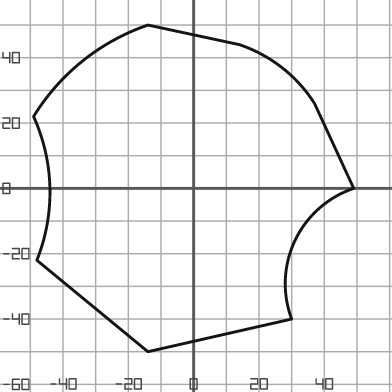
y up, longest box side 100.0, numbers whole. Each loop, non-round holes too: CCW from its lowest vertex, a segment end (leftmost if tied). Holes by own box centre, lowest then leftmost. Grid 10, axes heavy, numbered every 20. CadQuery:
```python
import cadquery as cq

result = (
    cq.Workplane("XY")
    .moveTo(-14.0, -50.0)
    .lineTo(30.0, -40.0)
    .threePointArc((31.0, -16.0), (49.0, 0.0))
    .lineTo(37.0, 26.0)
    .threePointArc((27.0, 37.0), (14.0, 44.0))
    .lineTo(-14.0, 50.0)
    .threePointArc((-34.0, 39.0), (-49.0, 22.0))
    .threePointArc((-44.0, 0.0), (-48.0, -22.0))
    .close()
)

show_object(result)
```